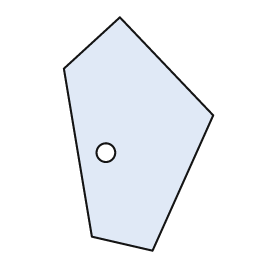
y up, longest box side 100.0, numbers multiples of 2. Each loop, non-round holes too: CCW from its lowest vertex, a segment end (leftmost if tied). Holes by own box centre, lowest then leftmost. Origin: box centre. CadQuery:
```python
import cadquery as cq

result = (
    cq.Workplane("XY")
    .moveTo(6.0, -50.0)
    .lineTo(32.0, 8.0)
    .lineTo(-8.0, 50.0)
    .lineTo(-32.0, 28.0)
    .lineTo(-20.0, -44.0)
    .close()
    .moveTo(-14.0, -8.0)
    .circle(4.0)
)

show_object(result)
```